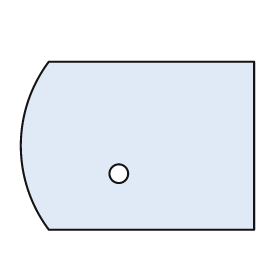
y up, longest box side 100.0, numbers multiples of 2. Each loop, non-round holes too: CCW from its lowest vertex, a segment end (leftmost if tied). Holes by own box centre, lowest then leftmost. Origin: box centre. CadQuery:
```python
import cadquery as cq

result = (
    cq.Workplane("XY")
    .moveTo(-38.0, -36.0)
    .lineTo(50.0, -36.0)
    .lineTo(50.0, 36.0)
    .lineTo(-38.0, 36.0)
    .threePointArc((-50.0, 0.0), (-38.0, -36.0))
    .close()
    .moveTo(-8.0, -12.0)
    .circle(4.0)
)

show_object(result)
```